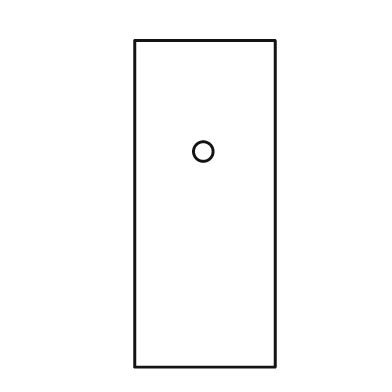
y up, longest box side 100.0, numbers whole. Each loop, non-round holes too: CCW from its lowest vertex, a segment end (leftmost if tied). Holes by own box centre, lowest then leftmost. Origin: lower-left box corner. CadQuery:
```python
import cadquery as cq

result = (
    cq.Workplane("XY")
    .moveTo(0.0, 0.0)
    .lineTo(43.0, 0.0)
    .lineTo(43.0, 100.0)
    .lineTo(0.0, 100.0)
    .close()
    .moveTo(21.0, 66.0)
    .circle(3.0)
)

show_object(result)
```